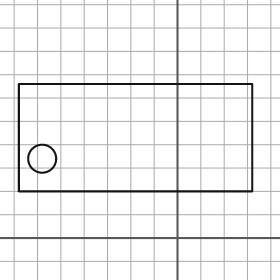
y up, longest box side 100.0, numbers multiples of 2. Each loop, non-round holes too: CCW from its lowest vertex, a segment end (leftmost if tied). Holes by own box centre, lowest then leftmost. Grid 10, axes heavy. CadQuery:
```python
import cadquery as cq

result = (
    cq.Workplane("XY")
    .moveTo(-68.0, 20.0)
    .lineTo(32.0, 20.0)
    .lineTo(32.0, 66.0)
    .lineTo(-68.0, 66.0)
    .close()
    .moveTo(-58.0, 34.0)
    .circle(6.0)
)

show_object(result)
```